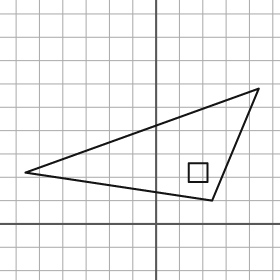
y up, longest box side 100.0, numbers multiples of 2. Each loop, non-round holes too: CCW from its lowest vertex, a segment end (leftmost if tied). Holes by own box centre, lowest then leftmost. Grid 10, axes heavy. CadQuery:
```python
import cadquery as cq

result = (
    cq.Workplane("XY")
    .moveTo(24.0, 10.0)
    .lineTo(44.0, 58.0)
    .lineTo(-56.0, 22.0)
    .close()
    .moveTo(14.0, 18.0)
    .lineTo(22.0, 18.0)
    .lineTo(22.0, 26.0)
    .lineTo(14.0, 26.0)
    .close()
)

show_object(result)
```